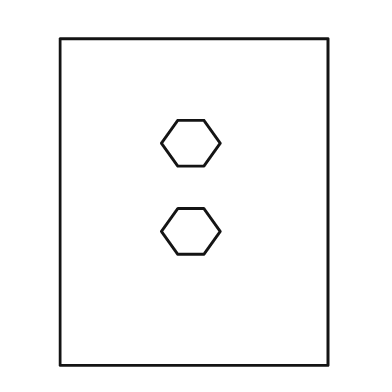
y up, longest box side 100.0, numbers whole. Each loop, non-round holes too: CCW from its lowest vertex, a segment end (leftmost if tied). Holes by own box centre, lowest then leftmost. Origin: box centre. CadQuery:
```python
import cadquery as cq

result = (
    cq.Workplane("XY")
    .moveTo(-41.0, -50.0)
    .lineTo(41.0, -50.0)
    .lineTo(41.0, 50.0)
    .lineTo(-41.0, 50.0)
    .close()
    .moveTo(-5.0, -16.0)
    .lineTo(3.0, -16.0)
    .lineTo(8.0, -9.0)
    .lineTo(3.0, -2.0)
    .lineTo(-5.0, -2.0)
    .lineTo(-10.0, -9.0)
    .close()
    .moveTo(-5.0, 11.0)
    .lineTo(3.0, 11.0)
    .lineTo(8.0, 18.0)
    .lineTo(3.0, 25.0)
    .lineTo(-5.0, 25.0)
    .lineTo(-10.0, 18.0)
    .close()
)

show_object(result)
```